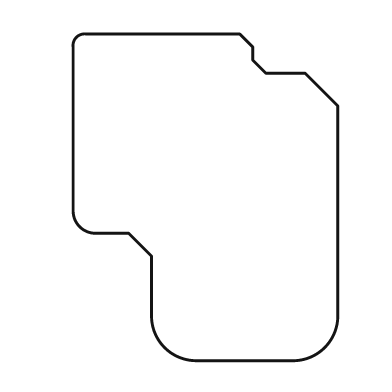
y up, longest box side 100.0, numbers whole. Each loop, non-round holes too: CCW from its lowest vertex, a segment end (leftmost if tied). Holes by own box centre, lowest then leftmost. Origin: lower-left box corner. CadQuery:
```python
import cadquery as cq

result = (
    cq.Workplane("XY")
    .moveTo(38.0, 0.0)
    .lineTo(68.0, 0.0)
    .threePointArc((77.0, 4.0), (81.0, 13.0))
    .lineTo(81.0, 78.0)
    .lineTo(71.0, 88.0)
    .lineTo(59.0, 88.0)
    .lineTo(55.0, 92.0)
    .lineTo(55.0, 96.0)
    .lineTo(51.0, 100.0)
    .lineTo(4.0, 100.0)
    .threePointArc((1.0, 99.0), (0.0, 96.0))
    .lineTo(0.0, 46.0)
    .threePointArc((2.0, 41.0), (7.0, 39.0))
    .lineTo(17.0, 39.0)
    .lineTo(24.0, 32.0)
    .lineTo(24.0, 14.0)
    .threePointArc((28.0, 4.0), (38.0, 0.0))
    .close()
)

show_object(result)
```